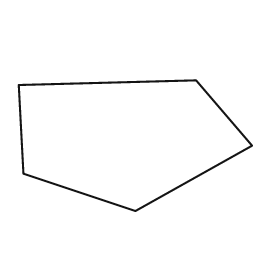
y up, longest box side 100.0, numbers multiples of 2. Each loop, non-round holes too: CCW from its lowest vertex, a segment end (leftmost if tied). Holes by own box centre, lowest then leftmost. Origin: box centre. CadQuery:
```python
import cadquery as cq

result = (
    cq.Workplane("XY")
    .moveTo(0.0, -28.0)
    .lineTo(50.0, 0.0)
    .lineTo(26.0, 28.0)
    .lineTo(-50.0, 26.0)
    .lineTo(-48.0, -12.0)
    .close()
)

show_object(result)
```